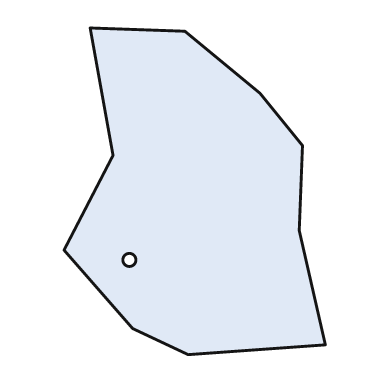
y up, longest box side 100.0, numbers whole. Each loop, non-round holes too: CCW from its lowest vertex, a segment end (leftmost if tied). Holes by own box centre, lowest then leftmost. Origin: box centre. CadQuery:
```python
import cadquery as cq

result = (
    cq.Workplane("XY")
    .moveTo(-2.0, -50.0)
    .lineTo(40.0, -47.0)
    .lineTo(32.0, -12.0)
    .lineTo(33.0, 14.0)
    .lineTo(20.0, 30.0)
    .lineTo(-3.0, 49.0)
    .lineTo(-32.0, 50.0)
    .lineTo(-25.0, 11.0)
    .lineTo(-40.0, -18.0)
    .lineTo(-19.0, -42.0)
    .close()
    .moveTo(-20.0, -21.0)
    .circle(2.0)
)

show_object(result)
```